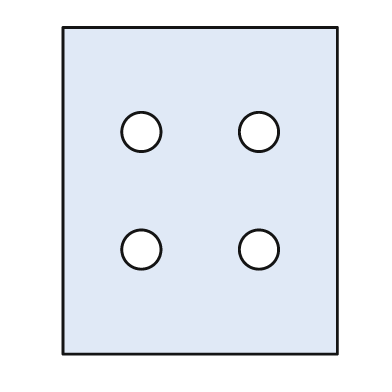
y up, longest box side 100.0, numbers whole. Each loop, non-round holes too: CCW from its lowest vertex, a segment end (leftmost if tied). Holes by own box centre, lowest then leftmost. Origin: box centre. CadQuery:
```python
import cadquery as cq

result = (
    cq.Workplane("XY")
    .moveTo(-42.0, -50.0)
    .lineTo(42.0, -50.0)
    .lineTo(42.0, 50.0)
    .lineTo(-42.0, 50.0)
    .close()
    .moveTo(-18.0, -18.0)
    .circle(6.0)
    .moveTo(18.0, -18.0)
    .circle(6.0)
    .moveTo(-18.0, 18.0)
    .circle(6.0)
    .moveTo(18.0, 18.0)
    .circle(6.0)
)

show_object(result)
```